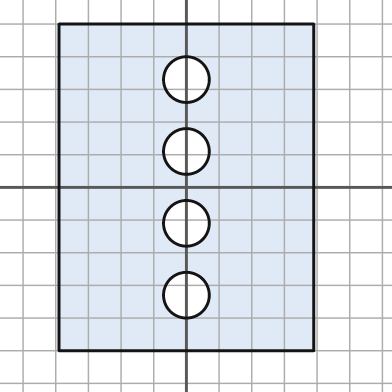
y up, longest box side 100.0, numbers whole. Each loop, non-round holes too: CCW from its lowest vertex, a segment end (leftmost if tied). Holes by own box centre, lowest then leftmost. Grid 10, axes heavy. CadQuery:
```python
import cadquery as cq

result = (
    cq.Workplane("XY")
    .moveTo(-39.0, -50.0)
    .lineTo(39.0, -50.0)
    .lineTo(39.0, 50.0)
    .lineTo(-39.0, 50.0)
    .close()
    .moveTo(0.0, -33.0)
    .circle(7.0)
    .moveTo(0.0, -11.0)
    .circle(7.0)
    .moveTo(0.0, 11.0)
    .circle(7.0)
    .moveTo(0.0, 33.0)
    .circle(7.0)
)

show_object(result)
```